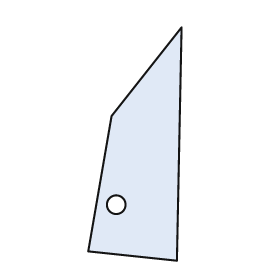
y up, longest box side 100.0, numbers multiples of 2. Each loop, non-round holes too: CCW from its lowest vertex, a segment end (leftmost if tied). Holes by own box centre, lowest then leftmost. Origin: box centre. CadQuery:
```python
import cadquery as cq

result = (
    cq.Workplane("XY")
    .moveTo(18.0, -50.0)
    .lineTo(20.0, 50.0)
    .lineTo(-10.0, 12.0)
    .lineTo(-20.0, -46.0)
    .close()
    .moveTo(-8.0, -26.0)
    .circle(4.0)
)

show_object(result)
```